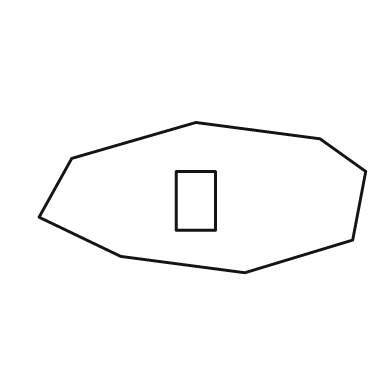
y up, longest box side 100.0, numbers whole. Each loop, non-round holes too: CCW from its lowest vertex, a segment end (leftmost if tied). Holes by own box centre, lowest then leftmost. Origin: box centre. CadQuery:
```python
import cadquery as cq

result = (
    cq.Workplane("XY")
    .moveTo(13.0, -23.0)
    .lineTo(46.0, -13.0)
    .lineTo(50.0, 8.0)
    .lineTo(36.0, 18.0)
    .lineTo(-2.0, 23.0)
    .lineTo(-40.0, 12.0)
    .lineTo(-50.0, -6.0)
    .lineTo(-25.0, -18.0)
    .close()
    .moveTo(-8.0, -10.0)
    .lineTo(4.0, -10.0)
    .lineTo(4.0, 8.0)
    .lineTo(-8.0, 8.0)
    .close()
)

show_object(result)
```